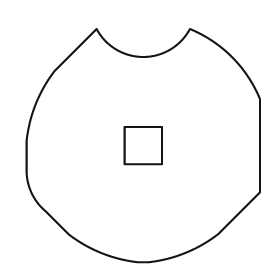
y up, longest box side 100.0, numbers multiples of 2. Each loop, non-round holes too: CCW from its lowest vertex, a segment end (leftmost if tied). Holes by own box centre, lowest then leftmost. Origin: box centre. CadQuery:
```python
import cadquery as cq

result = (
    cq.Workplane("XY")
    .moveTo(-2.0, -50.0)
    .lineTo(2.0, -50.0)
    .threePointArc((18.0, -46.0), (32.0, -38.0))
    .lineTo(50.0, -20.0)
    .lineTo(50.0, 20.0)
    .threePointArc((38.0, 38.0), (20.0, 50.0))
    .threePointArc((0.0, 38.0), (-20.0, 50.0))
    .lineTo(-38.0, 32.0)
    .threePointArc((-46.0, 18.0), (-50.0, 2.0))
    .lineTo(-50.0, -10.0)
    .threePointArc((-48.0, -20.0), (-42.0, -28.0))
    .lineTo(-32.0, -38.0)
    .threePointArc((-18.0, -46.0), (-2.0, -50.0))
    .close()
    .moveTo(-8.0, -8.0)
    .lineTo(8.0, -8.0)
    .lineTo(8.0, 8.0)
    .lineTo(-8.0, 8.0)
    .close()
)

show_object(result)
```